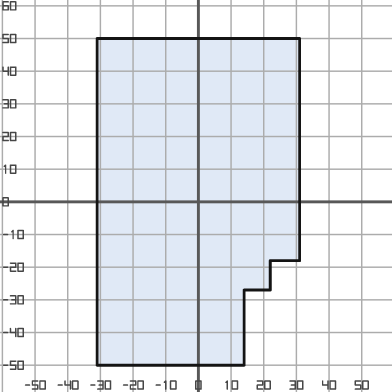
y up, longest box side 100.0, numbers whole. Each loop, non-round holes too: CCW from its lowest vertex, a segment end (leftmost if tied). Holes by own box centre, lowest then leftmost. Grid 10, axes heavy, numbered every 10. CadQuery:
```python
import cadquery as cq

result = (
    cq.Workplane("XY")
    .moveTo(-31.0, -50.0)
    .lineTo(14.0, -50.0)
    .lineTo(14.0, -27.0)
    .lineTo(22.0, -27.0)
    .lineTo(22.0, -18.0)
    .lineTo(31.0, -18.0)
    .lineTo(31.0, 50.0)
    .lineTo(-31.0, 50.0)
    .close()
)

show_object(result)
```